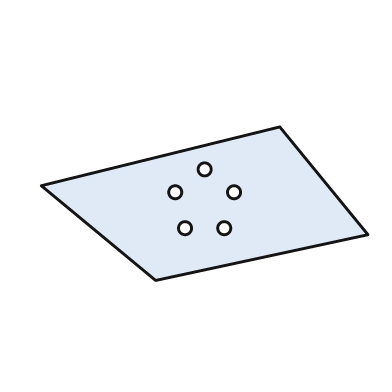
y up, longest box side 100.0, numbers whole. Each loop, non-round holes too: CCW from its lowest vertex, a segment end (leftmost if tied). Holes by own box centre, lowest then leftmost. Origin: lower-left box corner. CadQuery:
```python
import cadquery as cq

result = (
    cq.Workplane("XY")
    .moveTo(35.0, 0.0)
    .lineTo(100.0, 14.0)
    .lineTo(73.0, 47.0)
    .lineTo(0.0, 29.0)
    .close()
    .moveTo(44.0, 16.0)
    .circle(2.0)
    .moveTo(56.0, 16.0)
    .circle(2.0)
    .moveTo(41.0, 27.0)
    .circle(2.0)
    .moveTo(59.0, 27.0)
    .circle(2.0)
    .moveTo(50.0, 34.0)
    .circle(2.0)
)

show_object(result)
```